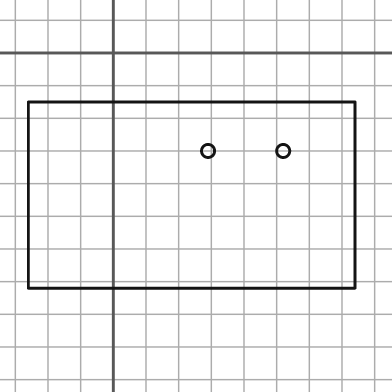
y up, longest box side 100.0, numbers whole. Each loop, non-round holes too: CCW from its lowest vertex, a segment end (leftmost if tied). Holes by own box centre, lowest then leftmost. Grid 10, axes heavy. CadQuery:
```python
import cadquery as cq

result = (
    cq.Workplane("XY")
    .moveTo(-26.0, -72.0)
    .lineTo(74.0, -72.0)
    .lineTo(74.0, -15.0)
    .lineTo(-26.0, -15.0)
    .close()
    .moveTo(29.0, -30.0)
    .circle(2.0)
    .moveTo(52.0, -30.0)
    .circle(2.0)
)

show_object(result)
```